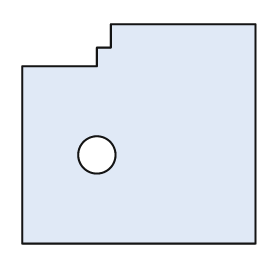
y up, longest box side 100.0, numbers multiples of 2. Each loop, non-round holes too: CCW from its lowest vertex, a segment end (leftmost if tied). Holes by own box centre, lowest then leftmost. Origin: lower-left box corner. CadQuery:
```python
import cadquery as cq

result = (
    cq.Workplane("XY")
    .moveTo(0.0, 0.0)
    .lineTo(100.0, 0.0)
    .lineTo(100.0, 94.0)
    .lineTo(38.0, 94.0)
    .lineTo(38.0, 84.0)
    .lineTo(32.0, 84.0)
    .lineTo(32.0, 76.0)
    .lineTo(0.0, 76.0)
    .close()
    .moveTo(32.0, 38.0)
    .circle(8.0)
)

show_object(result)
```